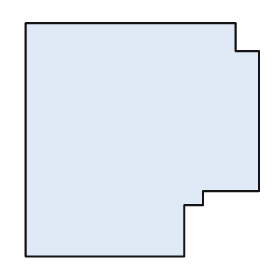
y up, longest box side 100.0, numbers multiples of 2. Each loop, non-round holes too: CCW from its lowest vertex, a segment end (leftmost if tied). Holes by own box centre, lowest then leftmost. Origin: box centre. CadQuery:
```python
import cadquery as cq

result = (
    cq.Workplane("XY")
    .moveTo(-50.0, -50.0)
    .lineTo(18.0, -50.0)
    .lineTo(18.0, -28.0)
    .lineTo(26.0, -28.0)
    .lineTo(26.0, -22.0)
    .lineTo(50.0, -22.0)
    .lineTo(50.0, 38.0)
    .lineTo(40.0, 38.0)
    .lineTo(40.0, 50.0)
    .lineTo(-50.0, 50.0)
    .close()
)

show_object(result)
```